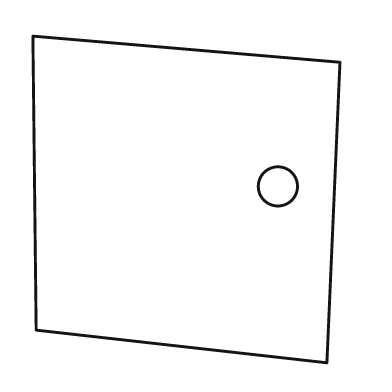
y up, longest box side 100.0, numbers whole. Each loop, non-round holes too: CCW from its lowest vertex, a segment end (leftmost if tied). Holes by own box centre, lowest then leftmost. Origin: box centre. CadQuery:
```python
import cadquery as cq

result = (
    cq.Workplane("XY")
    .moveTo(43.0, -50.0)
    .lineTo(47.0, 42.0)
    .lineTo(-47.0, 50.0)
    .lineTo(-46.0, -40.0)
    .close()
    .moveTo(28.0, 4.0)
    .circle(6.0)
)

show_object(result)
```